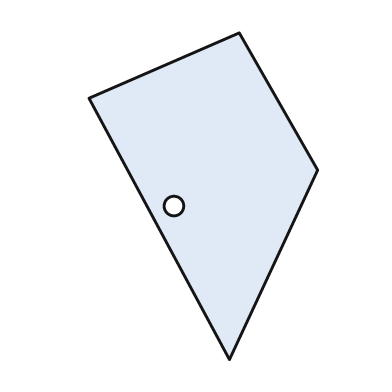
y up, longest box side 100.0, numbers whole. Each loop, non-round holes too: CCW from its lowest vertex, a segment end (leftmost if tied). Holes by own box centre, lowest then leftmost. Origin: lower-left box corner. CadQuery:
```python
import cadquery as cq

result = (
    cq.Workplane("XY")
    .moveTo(43.0, 0.0)
    .lineTo(70.0, 58.0)
    .lineTo(46.0, 100.0)
    .lineTo(0.0, 80.0)
    .close()
    .moveTo(26.0, 47.0)
    .circle(3.0)
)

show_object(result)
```